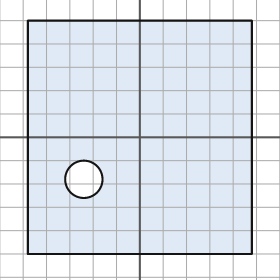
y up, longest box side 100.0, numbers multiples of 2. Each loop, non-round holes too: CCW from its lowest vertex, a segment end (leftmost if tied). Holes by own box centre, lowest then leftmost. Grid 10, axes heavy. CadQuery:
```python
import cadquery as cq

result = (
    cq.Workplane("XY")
    .moveTo(-48.0, -50.0)
    .lineTo(48.0, -50.0)
    .lineTo(48.0, 50.0)
    .lineTo(-48.0, 50.0)
    .close()
    .moveTo(-24.0, -18.0)
    .circle(8.0)
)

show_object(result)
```